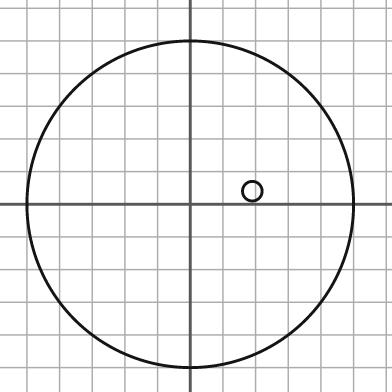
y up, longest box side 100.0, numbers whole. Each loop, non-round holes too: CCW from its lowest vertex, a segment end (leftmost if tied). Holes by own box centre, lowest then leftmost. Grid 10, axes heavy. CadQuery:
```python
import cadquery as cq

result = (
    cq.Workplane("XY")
    .moveTo(0.0, 0.0)
    .circle(50.0)
    .moveTo(19.0, 4.0)
    .circle(3.0)
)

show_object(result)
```